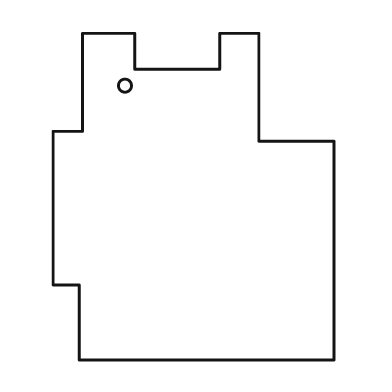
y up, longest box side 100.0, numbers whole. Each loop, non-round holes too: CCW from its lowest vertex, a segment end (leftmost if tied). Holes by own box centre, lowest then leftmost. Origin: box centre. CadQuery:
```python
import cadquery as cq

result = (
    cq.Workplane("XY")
    .moveTo(-35.0, -50.0)
    .lineTo(43.0, -50.0)
    .lineTo(43.0, 17.0)
    .lineTo(20.0, 17.0)
    .lineTo(20.0, 50.0)
    .lineTo(8.0, 50.0)
    .lineTo(8.0, 39.0)
    .lineTo(-18.0, 39.0)
    .lineTo(-18.0, 50.0)
    .lineTo(-34.0, 50.0)
    .lineTo(-34.0, 20.0)
    .lineTo(-43.0, 20.0)
    .lineTo(-43.0, -27.0)
    .lineTo(-35.0, -27.0)
    .close()
    .moveTo(-21.0, 34.0)
    .circle(2.0)
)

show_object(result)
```